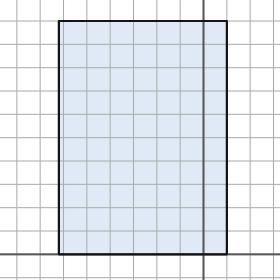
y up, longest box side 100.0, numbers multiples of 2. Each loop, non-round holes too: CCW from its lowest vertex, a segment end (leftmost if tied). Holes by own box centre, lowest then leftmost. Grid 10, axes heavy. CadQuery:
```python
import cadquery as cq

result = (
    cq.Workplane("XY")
    .moveTo(-62.0, 0.0)
    .lineTo(10.0, 0.0)
    .lineTo(10.0, 100.0)
    .lineTo(-62.0, 100.0)
    .close()
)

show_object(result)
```